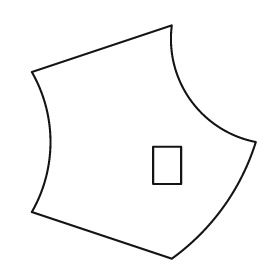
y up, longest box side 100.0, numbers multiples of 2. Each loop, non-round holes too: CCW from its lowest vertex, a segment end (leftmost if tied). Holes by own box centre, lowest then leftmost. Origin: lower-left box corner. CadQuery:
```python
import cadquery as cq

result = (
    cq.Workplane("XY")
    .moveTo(60.0, 0.0)
    .threePointArc((82.0, 22.0), (96.0, 50.0))
    .threePointArc((68.0, 68.0), (60.0, 100.0))
    .lineTo(0.0, 80.0)
    .threePointArc((8.0, 50.0), (0.0, 20.0))
    .close()
    .moveTo(52.0, 32.0)
    .lineTo(64.0, 32.0)
    .lineTo(64.0, 48.0)
    .lineTo(52.0, 48.0)
    .close()
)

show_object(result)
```